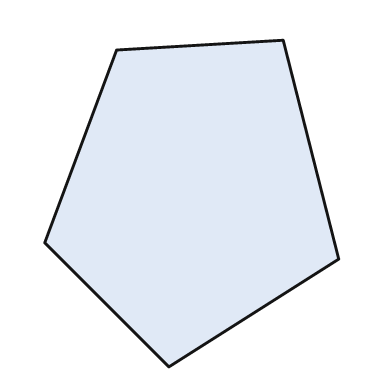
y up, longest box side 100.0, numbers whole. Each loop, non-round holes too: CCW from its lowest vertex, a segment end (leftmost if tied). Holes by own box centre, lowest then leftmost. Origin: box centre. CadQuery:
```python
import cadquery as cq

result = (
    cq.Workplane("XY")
    .moveTo(-7.0, -50.0)
    .lineTo(45.0, -17.0)
    .lineTo(28.0, 50.0)
    .lineTo(-23.0, 47.0)
    .lineTo(-45.0, -12.0)
    .close()
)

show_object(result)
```